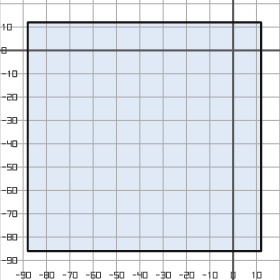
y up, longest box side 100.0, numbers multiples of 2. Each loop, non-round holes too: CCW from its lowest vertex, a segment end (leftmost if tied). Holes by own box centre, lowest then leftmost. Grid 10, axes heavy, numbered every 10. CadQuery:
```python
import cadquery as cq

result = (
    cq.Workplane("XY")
    .moveTo(-88.0, -86.0)
    .lineTo(12.0, -86.0)
    .lineTo(12.0, 12.0)
    .lineTo(-88.0, 12.0)
    .close()
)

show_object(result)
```